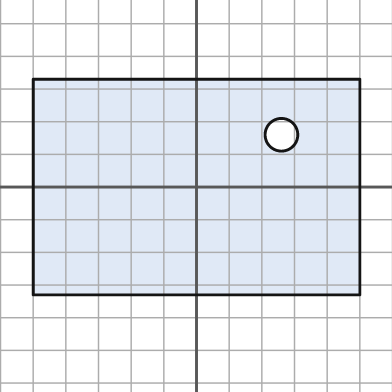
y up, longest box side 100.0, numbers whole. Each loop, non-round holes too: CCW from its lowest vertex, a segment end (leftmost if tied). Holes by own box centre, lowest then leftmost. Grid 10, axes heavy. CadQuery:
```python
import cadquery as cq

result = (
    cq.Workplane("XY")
    .moveTo(-50.0, -33.0)
    .lineTo(50.0, -33.0)
    .lineTo(50.0, 33.0)
    .lineTo(-50.0, 33.0)
    .close()
    .moveTo(26.0, 16.0)
    .circle(5.0)
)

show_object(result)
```